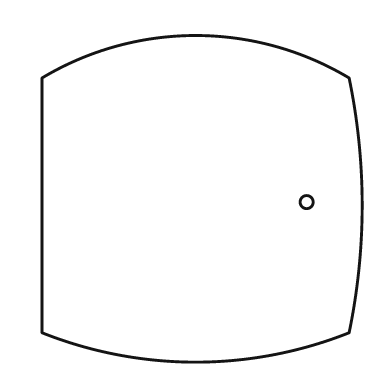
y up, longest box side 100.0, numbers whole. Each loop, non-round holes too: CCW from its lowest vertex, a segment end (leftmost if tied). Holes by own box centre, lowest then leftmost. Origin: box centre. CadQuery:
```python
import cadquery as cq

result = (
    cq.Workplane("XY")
    .moveTo(-49.0, -41.0)
    .threePointArc((-2.0, -50.0), (45.0, -41.0))
    .threePointArc((49.0, -2.0), (45.0, 37.0))
    .threePointArc((-2.0, 50.0), (-49.0, 37.0))
    .close()
    .moveTo(32.0, -1.0)
    .circle(2.0)
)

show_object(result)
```